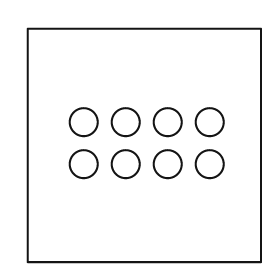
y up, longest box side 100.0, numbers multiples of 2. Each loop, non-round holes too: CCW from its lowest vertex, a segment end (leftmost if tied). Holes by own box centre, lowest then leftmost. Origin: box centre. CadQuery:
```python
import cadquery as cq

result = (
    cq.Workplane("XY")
    .moveTo(-50.0, -50.0)
    .lineTo(50.0, -50.0)
    .lineTo(50.0, 50.0)
    .lineTo(-50.0, 50.0)
    .close()
    .moveTo(-26.0, -8.0)
    .circle(6.0)
    .moveTo(-8.0, -8.0)
    .circle(6.0)
    .moveTo(10.0, -8.0)
    .circle(6.0)
    .moveTo(28.0, -8.0)
    .circle(6.0)
    .moveTo(-26.0, 10.0)
    .circle(6.0)
    .moveTo(-8.0, 10.0)
    .circle(6.0)
    .moveTo(10.0, 10.0)
    .circle(6.0)
    .moveTo(28.0, 10.0)
    .circle(6.0)
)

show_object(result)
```